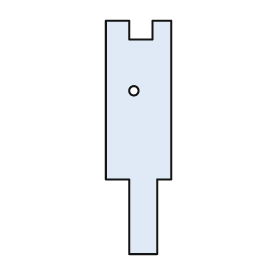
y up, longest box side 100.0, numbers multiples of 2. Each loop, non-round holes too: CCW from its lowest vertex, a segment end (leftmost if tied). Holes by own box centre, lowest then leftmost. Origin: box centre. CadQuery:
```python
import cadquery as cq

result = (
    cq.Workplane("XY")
    .moveTo(-4.0, -50.0)
    .lineTo(8.0, -50.0)
    .lineTo(8.0, -18.0)
    .lineTo(14.0, -18.0)
    .lineTo(14.0, 50.0)
    .lineTo(6.0, 50.0)
    .lineTo(6.0, 42.0)
    .lineTo(-4.0, 42.0)
    .lineTo(-4.0, 50.0)
    .lineTo(-14.0, 50.0)
    .lineTo(-14.0, -18.0)
    .lineTo(-4.0, -18.0)
    .close()
    .moveTo(-2.0, 20.0)
    .circle(2.0)
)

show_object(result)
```